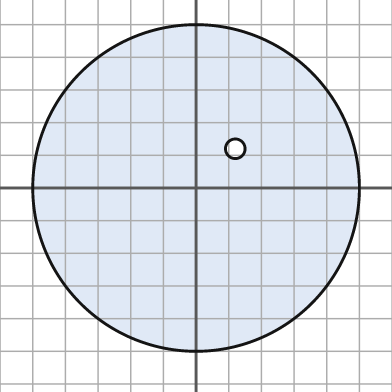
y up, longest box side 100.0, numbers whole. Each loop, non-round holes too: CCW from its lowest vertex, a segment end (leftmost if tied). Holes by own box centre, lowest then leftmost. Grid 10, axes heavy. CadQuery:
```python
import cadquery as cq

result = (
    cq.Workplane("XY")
    .moveTo(0.0, 0.0)
    .circle(50.0)
    .moveTo(12.0, 12.0)
    .circle(3.0)
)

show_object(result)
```